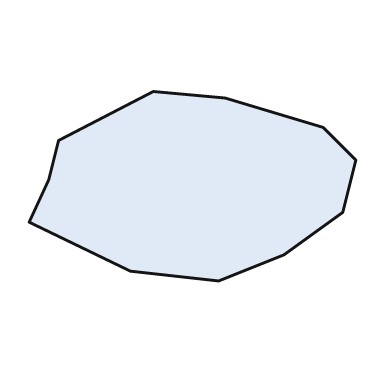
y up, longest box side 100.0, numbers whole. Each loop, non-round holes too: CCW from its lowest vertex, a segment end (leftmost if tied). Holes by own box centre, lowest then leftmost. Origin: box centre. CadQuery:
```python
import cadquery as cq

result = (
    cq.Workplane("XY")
    .moveTo(8.0, -29.0)
    .lineTo(28.0, -21.0)
    .lineTo(46.0, -8.0)
    .lineTo(50.0, 8.0)
    .lineTo(40.0, 18.0)
    .lineTo(10.0, 27.0)
    .lineTo(-12.0, 29.0)
    .lineTo(-41.0, 14.0)
    .lineTo(-44.0, 2.0)
    .lineTo(-50.0, -11.0)
    .lineTo(-19.0, -26.0)
    .close()
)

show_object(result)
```